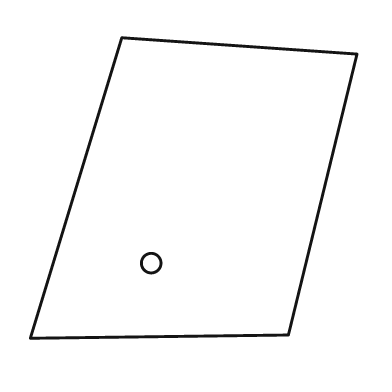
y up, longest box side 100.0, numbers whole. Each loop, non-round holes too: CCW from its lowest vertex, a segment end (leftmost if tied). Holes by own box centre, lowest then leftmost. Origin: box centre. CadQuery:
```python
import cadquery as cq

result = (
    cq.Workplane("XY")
    .moveTo(-50.0, -46.0)
    .lineTo(29.0, -45.0)
    .lineTo(50.0, 41.0)
    .lineTo(-22.0, 46.0)
    .close()
    .moveTo(-13.0, -23.0)
    .circle(3.0)
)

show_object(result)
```